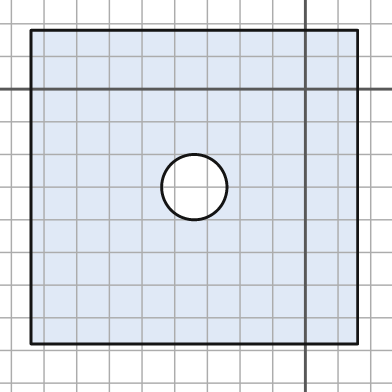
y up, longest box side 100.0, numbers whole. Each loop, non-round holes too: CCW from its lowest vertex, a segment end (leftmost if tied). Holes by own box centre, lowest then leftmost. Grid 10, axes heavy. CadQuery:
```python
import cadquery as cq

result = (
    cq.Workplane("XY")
    .moveTo(-84.0, -78.0)
    .lineTo(16.0, -78.0)
    .lineTo(16.0, 18.0)
    .lineTo(-84.0, 18.0)
    .close()
    .moveTo(-34.0, -30.0)
    .circle(10.0)
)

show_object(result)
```